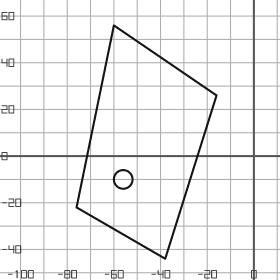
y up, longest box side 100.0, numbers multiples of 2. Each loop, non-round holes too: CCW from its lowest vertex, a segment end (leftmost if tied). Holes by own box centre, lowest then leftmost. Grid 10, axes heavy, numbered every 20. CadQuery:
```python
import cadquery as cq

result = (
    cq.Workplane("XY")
    .moveTo(-38.0, -44.0)
    .lineTo(-16.0, 26.0)
    .lineTo(-60.0, 56.0)
    .lineTo(-76.0, -22.0)
    .close()
    .moveTo(-56.0, -10.0)
    .circle(4.0)
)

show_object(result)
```